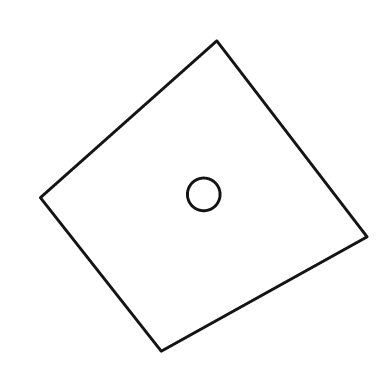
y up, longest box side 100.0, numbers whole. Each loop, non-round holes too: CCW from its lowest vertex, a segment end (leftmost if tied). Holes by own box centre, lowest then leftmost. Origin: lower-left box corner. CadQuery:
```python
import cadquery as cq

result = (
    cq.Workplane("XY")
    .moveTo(37.0, 0.0)
    .lineTo(100.0, 35.0)
    .lineTo(54.0, 95.0)
    .lineTo(0.0, 47.0)
    .close()
    .moveTo(50.0, 48.0)
    .circle(5.0)
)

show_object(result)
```